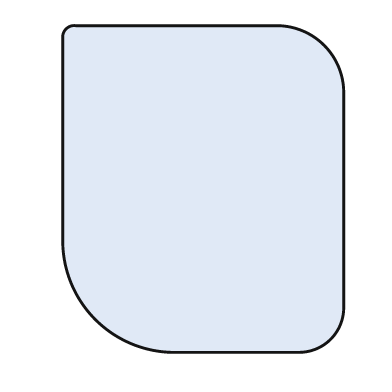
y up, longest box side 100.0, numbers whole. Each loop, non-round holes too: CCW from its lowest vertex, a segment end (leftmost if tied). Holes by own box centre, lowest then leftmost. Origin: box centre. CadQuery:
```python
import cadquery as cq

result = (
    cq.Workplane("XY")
    .moveTo(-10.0, -50.0)
    .lineTo(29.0, -50.0)
    .threePointArc((39.0, -46.0), (43.0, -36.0))
    .lineTo(43.0, 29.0)
    .threePointArc((37.0, 44.0), (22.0, 50.0))
    .lineTo(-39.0, 50.0)
    .threePointArc((-42.0, 49.0), (-43.0, 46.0))
    .lineTo(-43.0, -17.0)
    .threePointArc((-33.0, -40.0), (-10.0, -50.0))
    .close()
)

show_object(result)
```